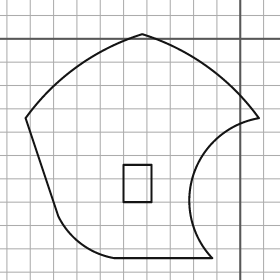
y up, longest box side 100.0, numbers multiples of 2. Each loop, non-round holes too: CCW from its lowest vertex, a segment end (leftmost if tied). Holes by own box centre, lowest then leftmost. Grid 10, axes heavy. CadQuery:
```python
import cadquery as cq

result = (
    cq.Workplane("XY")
    .moveTo(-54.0, -94.0)
    .lineTo(-12.0, -94.0)
    .threePointArc((-20.0, -58.0), (8.0, -34.0))
    .threePointArc((-14.0, -12.0), (-42.0, 2.0))
    .threePointArc((-70.0, -12.0), (-92.0, -34.0))
    .lineTo(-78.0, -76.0)
    .threePointArc((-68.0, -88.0), (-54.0, -94.0))
    .close()
    .moveTo(-50.0, -70.0)
    .lineTo(-38.0, -70.0)
    .lineTo(-38.0, -54.0)
    .lineTo(-50.0, -54.0)
    .close()
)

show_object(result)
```